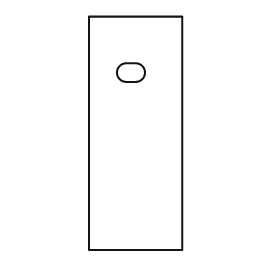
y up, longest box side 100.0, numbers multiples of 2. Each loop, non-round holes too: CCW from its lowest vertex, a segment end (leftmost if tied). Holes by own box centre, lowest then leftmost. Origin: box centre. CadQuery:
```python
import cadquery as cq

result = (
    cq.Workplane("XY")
    .moveTo(-20.0, -50.0)
    .lineTo(20.0, -50.0)
    .lineTo(20.0, 50.0)
    .lineTo(-20.0, 50.0)
    .close()
    .moveTo(-4.0, 22.0)
    .lineTo(0.0, 22.0)
    .threePointArc((4.0, 26.0), (0.0, 30.0))
    .lineTo(-4.0, 30.0)
    .threePointArc((-8.0, 26.0), (-4.0, 22.0))
    .close()
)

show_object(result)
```